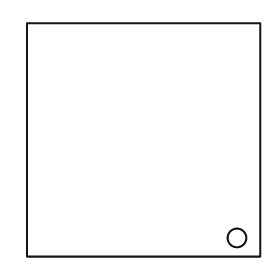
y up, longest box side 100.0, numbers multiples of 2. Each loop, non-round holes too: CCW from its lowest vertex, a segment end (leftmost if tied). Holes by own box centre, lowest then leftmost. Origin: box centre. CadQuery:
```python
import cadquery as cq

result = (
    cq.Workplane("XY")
    .moveTo(-50.0, -50.0)
    .lineTo(50.0, -50.0)
    .lineTo(50.0, 50.0)
    .lineTo(-50.0, 50.0)
    .close()
    .moveTo(40.0, -42.0)
    .circle(4.0)
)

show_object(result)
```